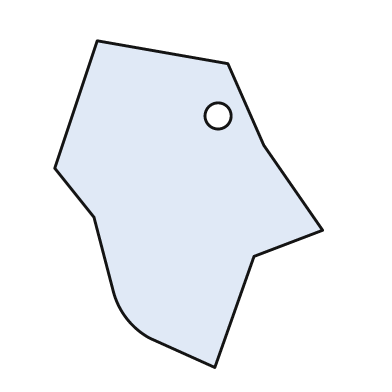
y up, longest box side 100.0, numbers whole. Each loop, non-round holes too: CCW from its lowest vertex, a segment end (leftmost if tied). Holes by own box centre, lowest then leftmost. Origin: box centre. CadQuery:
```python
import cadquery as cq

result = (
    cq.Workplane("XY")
    .moveTo(8.0, -50.0)
    .lineTo(20.0, -16.0)
    .lineTo(41.0, -8.0)
    .lineTo(23.0, 18.0)
    .lineTo(12.0, 43.0)
    .lineTo(-28.0, 50.0)
    .lineTo(-41.0, 11.0)
    .lineTo(-29.0, -4.0)
    .lineTo(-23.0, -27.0)
    .threePointArc((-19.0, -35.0), (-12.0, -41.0))
    .close()
    .moveTo(9.0, 27.0)
    .circle(4.0)
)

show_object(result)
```